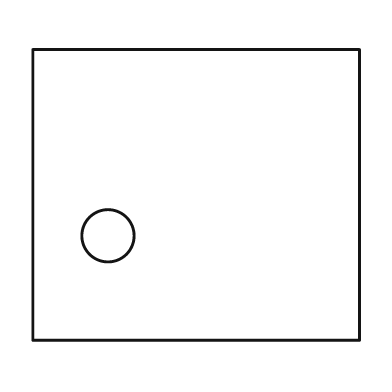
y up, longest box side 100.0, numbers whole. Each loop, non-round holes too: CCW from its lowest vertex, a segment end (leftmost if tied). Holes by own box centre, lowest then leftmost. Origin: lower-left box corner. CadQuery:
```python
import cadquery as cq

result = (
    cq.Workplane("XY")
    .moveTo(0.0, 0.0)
    .lineTo(100.0, 0.0)
    .lineTo(100.0, 89.0)
    .lineTo(0.0, 89.0)
    .close()
    .moveTo(23.0, 32.0)
    .circle(8.0)
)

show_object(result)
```